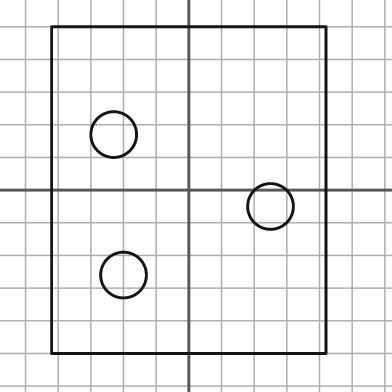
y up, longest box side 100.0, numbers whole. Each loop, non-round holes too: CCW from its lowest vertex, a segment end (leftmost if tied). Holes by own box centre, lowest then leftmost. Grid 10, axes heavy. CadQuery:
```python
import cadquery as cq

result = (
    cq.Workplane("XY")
    .moveTo(-42.0, -50.0)
    .lineTo(42.0, -50.0)
    .lineTo(42.0, 50.0)
    .lineTo(-42.0, 50.0)
    .close()
    .moveTo(-20.0, -26.0)
    .circle(7.0)
    .moveTo(25.0, -5.0)
    .circle(7.0)
    .moveTo(-23.0, 17.0)
    .circle(7.0)
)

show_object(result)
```